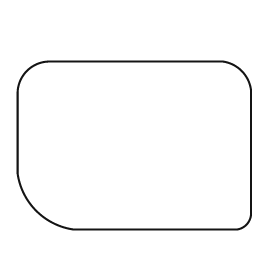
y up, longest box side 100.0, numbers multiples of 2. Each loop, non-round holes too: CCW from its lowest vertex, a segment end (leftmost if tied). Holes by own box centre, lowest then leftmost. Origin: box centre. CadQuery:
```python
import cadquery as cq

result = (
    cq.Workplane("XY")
    .moveTo(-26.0, -36.0)
    .lineTo(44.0, -36.0)
    .threePointArc((48.0, -34.0), (50.0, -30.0))
    .lineTo(50.0, 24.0)
    .threePointArc((46.0, 32.0), (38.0, 36.0))
    .lineTo(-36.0, 36.0)
    .threePointArc((-46.0, 32.0), (-50.0, 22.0))
    .lineTo(-50.0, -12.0)
    .threePointArc((-42.0, -28.0), (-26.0, -36.0))
    .close()
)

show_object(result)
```